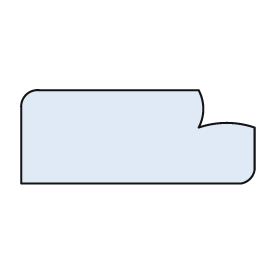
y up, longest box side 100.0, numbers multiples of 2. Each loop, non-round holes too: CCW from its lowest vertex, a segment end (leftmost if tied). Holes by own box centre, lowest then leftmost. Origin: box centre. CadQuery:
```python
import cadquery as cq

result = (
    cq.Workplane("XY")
    .moveTo(-50.0, -20.0)
    .lineTo(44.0, -20.0)
    .threePointArc((48.0, -18.0), (50.0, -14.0))
    .lineTo(50.0, 4.0)
    .threePointArc((38.0, 6.0), (26.0, 4.0))
    .threePointArc((28.0, 12.0), (26.0, 20.0))
    .lineTo(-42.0, 20.0)
    .threePointArc((-48.0, 18.0), (-50.0, 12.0))
    .close()
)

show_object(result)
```